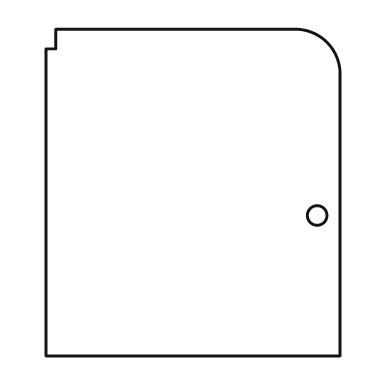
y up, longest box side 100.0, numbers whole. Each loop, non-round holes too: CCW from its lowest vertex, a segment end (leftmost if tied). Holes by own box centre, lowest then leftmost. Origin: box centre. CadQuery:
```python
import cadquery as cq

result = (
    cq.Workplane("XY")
    .moveTo(-45.0, -50.0)
    .lineTo(45.0, -50.0)
    .lineTo(45.0, 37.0)
    .threePointArc((41.0, 46.0), (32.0, 50.0))
    .lineTo(-42.0, 50.0)
    .lineTo(-42.0, 44.0)
    .lineTo(-45.0, 44.0)
    .close()
    .moveTo(38.0, -7.0)
    .circle(3.0)
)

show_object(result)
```